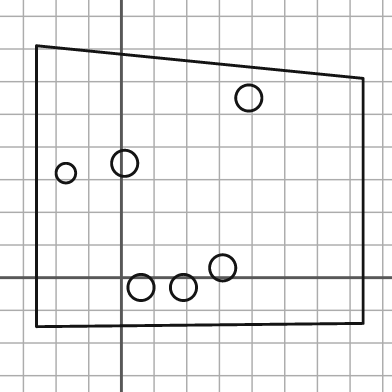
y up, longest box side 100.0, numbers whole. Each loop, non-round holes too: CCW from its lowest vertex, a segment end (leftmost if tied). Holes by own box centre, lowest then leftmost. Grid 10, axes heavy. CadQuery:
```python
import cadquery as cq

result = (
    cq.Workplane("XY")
    .moveTo(-26.0, -15.0)
    .lineTo(74.0, -14.0)
    .lineTo(74.0, 61.0)
    .lineTo(-26.0, 71.0)
    .close()
    .moveTo(6.0, -3.0)
    .circle(4.0)
    .moveTo(19.0, -3.0)
    .circle(4.0)
    .moveTo(31.0, 3.0)
    .circle(4.0)
    .moveTo(-17.0, 32.0)
    .circle(3.0)
    .moveTo(1.0, 35.0)
    .circle(4.0)
    .moveTo(39.0, 55.0)
    .circle(4.0)
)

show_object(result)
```